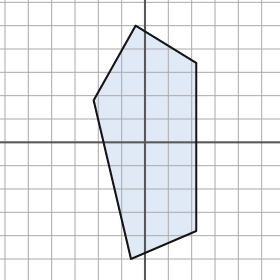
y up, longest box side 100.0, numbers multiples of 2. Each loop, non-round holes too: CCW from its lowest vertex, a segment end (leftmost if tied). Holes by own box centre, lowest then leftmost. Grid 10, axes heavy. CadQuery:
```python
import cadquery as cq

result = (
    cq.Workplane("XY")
    .moveTo(-6.0, -50.0)
    .lineTo(22.0, -38.0)
    .lineTo(22.0, 34.0)
    .lineTo(-4.0, 50.0)
    .lineTo(-22.0, 18.0)
    .close()
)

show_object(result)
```